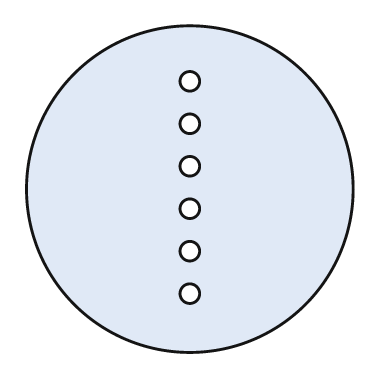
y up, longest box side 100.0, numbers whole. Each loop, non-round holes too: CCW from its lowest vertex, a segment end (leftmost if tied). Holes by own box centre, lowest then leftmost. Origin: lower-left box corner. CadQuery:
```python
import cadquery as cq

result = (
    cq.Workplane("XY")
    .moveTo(50.0, 50.0)
    .circle(50.0)
    .moveTo(50.0, 18.0)
    .circle(3.0)
    .moveTo(50.0, 31.0)
    .circle(3.0)
    .moveTo(50.0, 44.0)
    .circle(3.0)
    .moveTo(50.0, 57.0)
    .circle(3.0)
    .moveTo(50.0, 70.0)
    .circle(3.0)
    .moveTo(50.0, 83.0)
    .circle(3.0)
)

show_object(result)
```